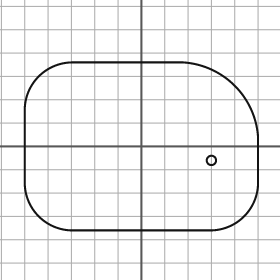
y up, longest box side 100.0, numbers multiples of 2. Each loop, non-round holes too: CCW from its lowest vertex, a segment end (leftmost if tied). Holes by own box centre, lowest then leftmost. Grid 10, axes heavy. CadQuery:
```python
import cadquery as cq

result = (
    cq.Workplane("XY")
    .moveTo(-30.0, -36.0)
    .lineTo(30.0, -36.0)
    .threePointArc((44.0, -30.0), (50.0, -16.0))
    .lineTo(50.0, 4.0)
    .threePointArc((40.0, 26.0), (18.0, 36.0))
    .lineTo(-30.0, 36.0)
    .threePointArc((-44.0, 30.0), (-50.0, 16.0))
    .lineTo(-50.0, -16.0)
    .threePointArc((-44.0, -30.0), (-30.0, -36.0))
    .close()
    .moveTo(30.0, -6.0)
    .circle(2.0)
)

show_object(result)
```